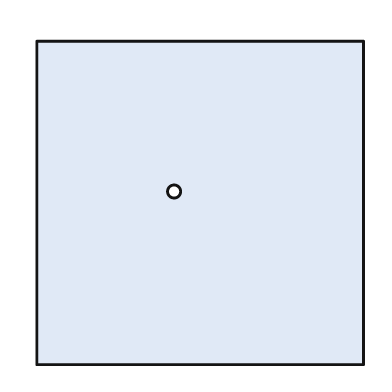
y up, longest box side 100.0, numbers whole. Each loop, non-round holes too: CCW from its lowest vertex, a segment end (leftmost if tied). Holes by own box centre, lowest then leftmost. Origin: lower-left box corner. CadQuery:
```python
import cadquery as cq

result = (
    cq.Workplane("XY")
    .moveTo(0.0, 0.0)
    .lineTo(100.0, 0.0)
    .lineTo(100.0, 99.0)
    .lineTo(0.0, 99.0)
    .close()
    .moveTo(42.0, 53.0)
    .circle(2.0)
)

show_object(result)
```